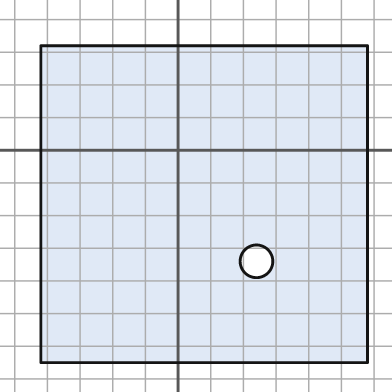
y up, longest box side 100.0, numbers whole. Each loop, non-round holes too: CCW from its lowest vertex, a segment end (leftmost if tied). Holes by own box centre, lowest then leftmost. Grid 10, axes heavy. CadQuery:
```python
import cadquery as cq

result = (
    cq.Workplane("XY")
    .moveTo(-42.0, -65.0)
    .lineTo(58.0, -65.0)
    .lineTo(58.0, 32.0)
    .lineTo(-42.0, 32.0)
    .close()
    .moveTo(24.0, -34.0)
    .circle(5.0)
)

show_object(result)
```